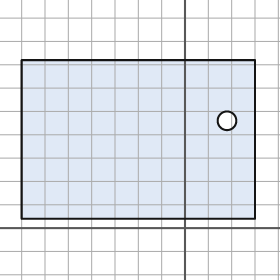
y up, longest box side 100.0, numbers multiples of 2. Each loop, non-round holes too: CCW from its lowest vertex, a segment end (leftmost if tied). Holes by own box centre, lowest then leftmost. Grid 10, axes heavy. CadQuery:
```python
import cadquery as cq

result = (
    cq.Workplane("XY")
    .moveTo(-70.0, 4.0)
    .lineTo(30.0, 4.0)
    .lineTo(30.0, 72.0)
    .lineTo(-70.0, 72.0)
    .close()
    .moveTo(18.0, 46.0)
    .circle(4.0)
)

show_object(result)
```